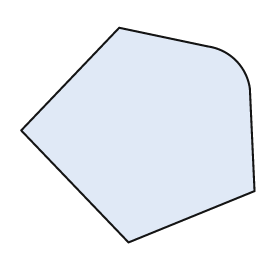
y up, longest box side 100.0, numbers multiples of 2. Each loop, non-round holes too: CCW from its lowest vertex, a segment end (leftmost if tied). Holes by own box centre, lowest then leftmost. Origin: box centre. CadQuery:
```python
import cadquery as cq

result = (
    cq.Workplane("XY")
    .moveTo(-4.0, -46.0)
    .lineTo(50.0, -24.0)
    .lineTo(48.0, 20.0)
    .threePointArc((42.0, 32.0), (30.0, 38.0))
    .lineTo(-8.0, 46.0)
    .lineTo(-50.0, 2.0)
    .close()
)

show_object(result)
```